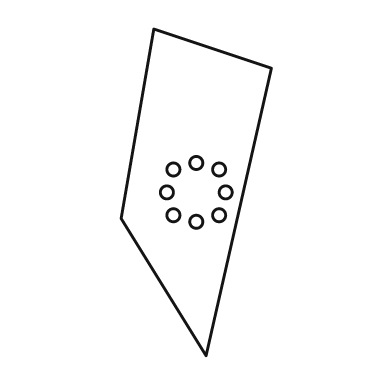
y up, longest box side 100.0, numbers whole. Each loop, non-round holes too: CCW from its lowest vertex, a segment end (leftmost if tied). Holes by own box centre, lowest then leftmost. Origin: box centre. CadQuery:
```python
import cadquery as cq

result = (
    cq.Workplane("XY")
    .moveTo(3.0, -50.0)
    .lineTo(23.0, 38.0)
    .lineTo(-13.0, 50.0)
    .lineTo(-23.0, -8.0)
    .close()
    .moveTo(0.0, -9.0)
    .circle(2.0)
    .moveTo(-7.0, -7.0)
    .circle(2.0)
    .moveTo(7.0, -7.0)
    .circle(2.0)
    .moveTo(-9.0, 0.0)
    .circle(2.0)
    .moveTo(9.0, 0.0)
    .circle(2.0)
    .moveTo(-7.0, 7.0)
    .circle(2.0)
    .moveTo(7.0, 7.0)
    .circle(2.0)
    .moveTo(0.0, 9.0)
    .circle(2.0)
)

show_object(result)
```